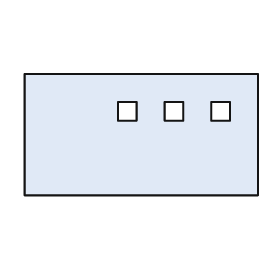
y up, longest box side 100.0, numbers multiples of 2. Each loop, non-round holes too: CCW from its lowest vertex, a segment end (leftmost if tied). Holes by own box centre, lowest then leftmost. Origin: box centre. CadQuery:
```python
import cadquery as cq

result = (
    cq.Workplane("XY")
    .moveTo(-50.0, -26.0)
    .lineTo(50.0, -26.0)
    .lineTo(50.0, 26.0)
    .lineTo(-50.0, 26.0)
    .close()
    .moveTo(-10.0, 6.0)
    .lineTo(-2.0, 6.0)
    .lineTo(-2.0, 14.0)
    .lineTo(-10.0, 14.0)
    .close()
    .moveTo(10.0, 6.0)
    .lineTo(18.0, 6.0)
    .lineTo(18.0, 14.0)
    .lineTo(10.0, 14.0)
    .close()
    .moveTo(30.0, 6.0)
    .lineTo(38.0, 6.0)
    .lineTo(38.0, 14.0)
    .lineTo(30.0, 14.0)
    .close()
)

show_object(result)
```